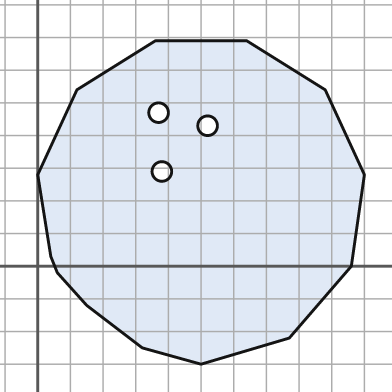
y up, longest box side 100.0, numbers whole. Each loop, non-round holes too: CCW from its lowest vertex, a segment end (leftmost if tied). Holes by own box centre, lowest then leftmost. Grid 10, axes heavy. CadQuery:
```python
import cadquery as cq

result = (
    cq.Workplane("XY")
    .moveTo(50.0, -30.0)
    .lineTo(77.0, -22.0)
    .lineTo(96.0, 0.0)
    .lineTo(100.0, 28.0)
    .lineTo(88.0, 54.0)
    .lineTo(64.0, 69.0)
    .lineTo(36.0, 69.0)
    .lineTo(12.0, 54.0)
    .lineTo(0.0, 28.0)
    .lineTo(4.0, 3.0)
    .lineTo(6.0, -2.0)
    .lineTo(15.0, -12.0)
    .lineTo(32.0, -25.0)
    .close()
    .moveTo(38.0, 29.0)
    .circle(3.0)
    .moveTo(52.0, 43.0)
    .circle(3.0)
    .moveTo(37.0, 47.0)
    .circle(3.0)
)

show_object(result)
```